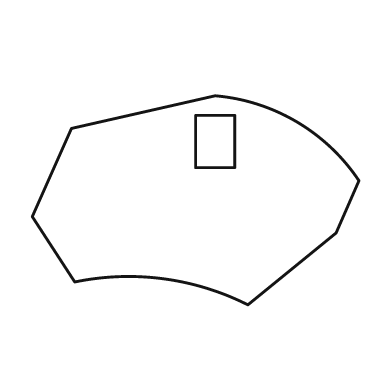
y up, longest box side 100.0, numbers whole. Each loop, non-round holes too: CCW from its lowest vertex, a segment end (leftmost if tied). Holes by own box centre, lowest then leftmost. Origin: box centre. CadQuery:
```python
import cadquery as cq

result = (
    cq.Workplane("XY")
    .moveTo(16.0, -32.0)
    .lineTo(43.0, -10.0)
    .lineTo(50.0, 6.0)
    .threePointArc((31.0, 24.0), (6.0, 32.0))
    .lineTo(-38.0, 22.0)
    .lineTo(-50.0, -5.0)
    .lineTo(-37.0, -25.0)
    .threePointArc((-10.0, -24.0), (16.0, -32.0))
    .close()
    .moveTo(0.0, 10.0)
    .lineTo(12.0, 10.0)
    .lineTo(12.0, 26.0)
    .lineTo(0.0, 26.0)
    .close()
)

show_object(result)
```